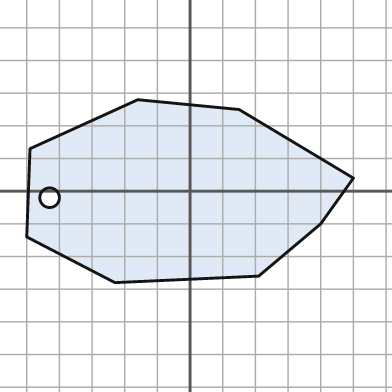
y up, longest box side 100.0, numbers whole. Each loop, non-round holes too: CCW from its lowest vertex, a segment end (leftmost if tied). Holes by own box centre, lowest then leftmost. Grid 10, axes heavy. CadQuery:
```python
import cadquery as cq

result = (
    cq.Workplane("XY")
    .moveTo(-23.0, -28.0)
    .lineTo(21.0, -26.0)
    .lineTo(40.0, -10.0)
    .lineTo(50.0, 4.0)
    .lineTo(15.0, 25.0)
    .lineTo(-16.0, 28.0)
    .lineTo(-49.0, 13.0)
    .lineTo(-50.0, -14.0)
    .close()
    .moveTo(-43.0, -2.0)
    .circle(3.0)
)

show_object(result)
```